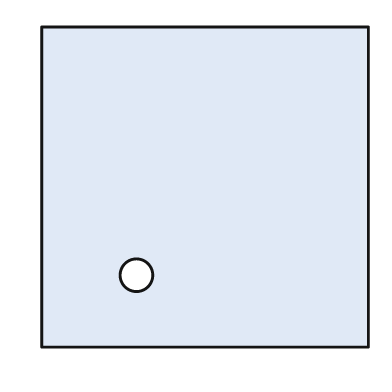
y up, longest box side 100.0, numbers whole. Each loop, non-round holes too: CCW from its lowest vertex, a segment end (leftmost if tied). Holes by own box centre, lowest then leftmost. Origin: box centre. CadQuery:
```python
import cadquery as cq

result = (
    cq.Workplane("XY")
    .moveTo(-50.0, -49.0)
    .lineTo(50.0, -49.0)
    .lineTo(50.0, 49.0)
    .lineTo(-50.0, 49.0)
    .close()
    .moveTo(-21.0, -27.0)
    .circle(5.0)
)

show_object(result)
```